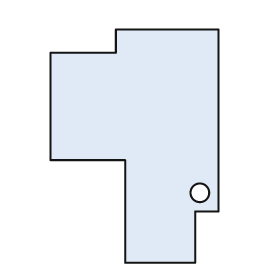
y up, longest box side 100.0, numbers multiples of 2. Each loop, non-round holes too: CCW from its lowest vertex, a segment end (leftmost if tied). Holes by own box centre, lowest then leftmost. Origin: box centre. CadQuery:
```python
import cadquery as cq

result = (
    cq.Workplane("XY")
    .moveTo(-4.0, -50.0)
    .lineTo(26.0, -50.0)
    .lineTo(26.0, -28.0)
    .lineTo(36.0, -28.0)
    .lineTo(36.0, 50.0)
    .lineTo(-8.0, 50.0)
    .lineTo(-8.0, 40.0)
    .lineTo(-36.0, 40.0)
    .lineTo(-36.0, -6.0)
    .lineTo(-4.0, -6.0)
    .close()
    .moveTo(28.0, -20.0)
    .circle(4.0)
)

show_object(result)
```